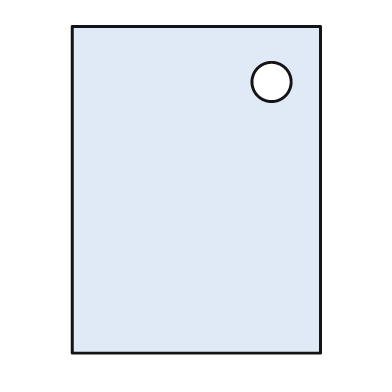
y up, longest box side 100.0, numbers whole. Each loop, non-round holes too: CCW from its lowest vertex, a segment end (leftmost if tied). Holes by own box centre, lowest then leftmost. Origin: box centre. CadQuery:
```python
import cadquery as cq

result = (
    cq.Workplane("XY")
    .moveTo(-38.0, -50.0)
    .lineTo(38.0, -50.0)
    .lineTo(38.0, 50.0)
    .lineTo(-38.0, 50.0)
    .close()
    .moveTo(23.0, 33.0)
    .circle(6.0)
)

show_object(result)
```